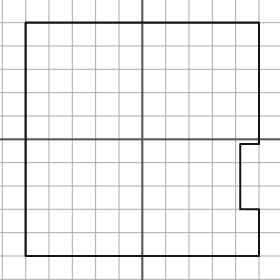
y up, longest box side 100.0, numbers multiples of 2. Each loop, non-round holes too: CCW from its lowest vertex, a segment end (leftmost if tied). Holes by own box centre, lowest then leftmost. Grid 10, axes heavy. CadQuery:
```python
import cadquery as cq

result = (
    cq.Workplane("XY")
    .moveTo(-50.0, -50.0)
    .lineTo(50.0, -50.0)
    .lineTo(50.0, -30.0)
    .lineTo(42.0, -30.0)
    .lineTo(42.0, -2.0)
    .lineTo(50.0, -2.0)
    .lineTo(50.0, 50.0)
    .lineTo(-50.0, 50.0)
    .close()
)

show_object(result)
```